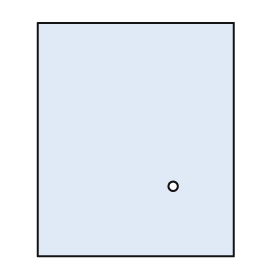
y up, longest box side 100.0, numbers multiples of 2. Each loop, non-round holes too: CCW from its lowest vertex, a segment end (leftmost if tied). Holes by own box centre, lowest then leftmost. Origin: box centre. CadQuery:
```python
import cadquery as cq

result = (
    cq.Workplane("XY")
    .moveTo(-42.0, -50.0)
    .lineTo(42.0, -50.0)
    .lineTo(42.0, 50.0)
    .lineTo(-42.0, 50.0)
    .close()
    .moveTo(16.0, -20.0)
    .circle(2.0)
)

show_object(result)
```